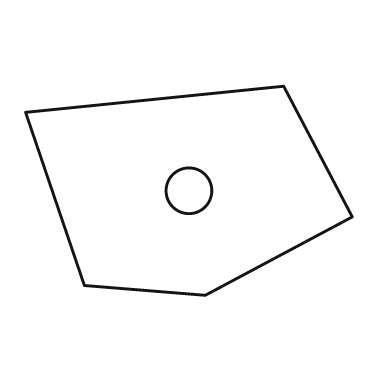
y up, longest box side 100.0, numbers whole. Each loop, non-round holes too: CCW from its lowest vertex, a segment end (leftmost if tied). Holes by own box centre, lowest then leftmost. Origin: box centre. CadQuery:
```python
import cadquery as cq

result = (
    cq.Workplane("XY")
    .moveTo(5.0, -32.0)
    .lineTo(50.0, -8.0)
    .lineTo(29.0, 32.0)
    .lineTo(-50.0, 24.0)
    .lineTo(-32.0, -29.0)
    .close()
    .moveTo(0.0, 0.0)
    .circle(7.0)
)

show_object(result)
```